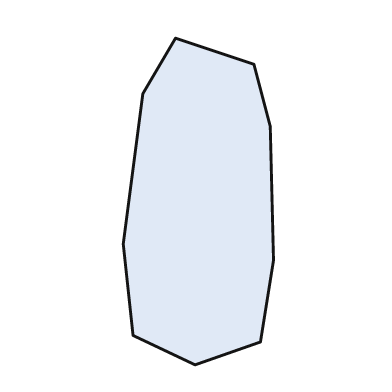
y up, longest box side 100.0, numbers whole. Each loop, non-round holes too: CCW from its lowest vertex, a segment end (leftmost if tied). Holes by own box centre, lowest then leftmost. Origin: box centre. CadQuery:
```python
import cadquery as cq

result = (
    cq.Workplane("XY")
    .moveTo(-1.0, -50.0)
    .lineTo(19.0, -43.0)
    .lineTo(23.0, -18.0)
    .lineTo(22.0, 23.0)
    .lineTo(17.0, 42.0)
    .lineTo(-7.0, 50.0)
    .lineTo(-17.0, 33.0)
    .lineTo(-23.0, -13.0)
    .lineTo(-20.0, -41.0)
    .close()
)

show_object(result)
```